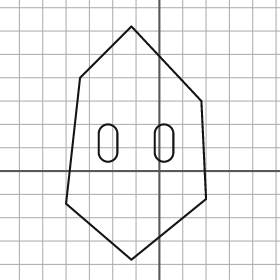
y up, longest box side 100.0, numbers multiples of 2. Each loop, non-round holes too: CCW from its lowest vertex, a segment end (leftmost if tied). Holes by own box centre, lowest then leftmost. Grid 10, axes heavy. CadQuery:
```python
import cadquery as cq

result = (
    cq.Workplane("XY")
    .moveTo(-12.0, -38.0)
    .lineTo(20.0, -12.0)
    .lineTo(18.0, 30.0)
    .lineTo(-12.0, 62.0)
    .lineTo(-34.0, 40.0)
    .lineTo(-40.0, -14.0)
    .close()
    .moveTo(-26.0, 8.0)
    .threePointArc((-22.0, 4.0), (-18.0, 8.0))
    .lineTo(-18.0, 16.0)
    .threePointArc((-22.0, 20.0), (-26.0, 16.0))
    .close()
    .moveTo(-2.0, 8.0)
    .threePointArc((2.0, 4.0), (6.0, 8.0))
    .lineTo(6.0, 16.0)
    .threePointArc((2.0, 20.0), (-2.0, 16.0))
    .close()
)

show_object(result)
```